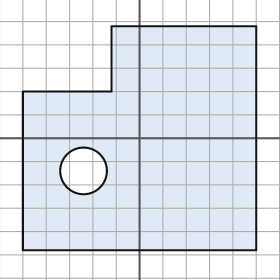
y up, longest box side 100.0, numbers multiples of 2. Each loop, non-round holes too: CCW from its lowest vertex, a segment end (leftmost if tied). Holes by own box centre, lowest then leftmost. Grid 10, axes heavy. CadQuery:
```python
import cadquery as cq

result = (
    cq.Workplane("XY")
    .moveTo(-50.0, -48.0)
    .lineTo(50.0, -48.0)
    .lineTo(50.0, 48.0)
    .lineTo(-12.0, 48.0)
    .lineTo(-12.0, 20.0)
    .lineTo(-50.0, 20.0)
    .close()
    .moveTo(-24.0, -14.0)
    .circle(10.0)
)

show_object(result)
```